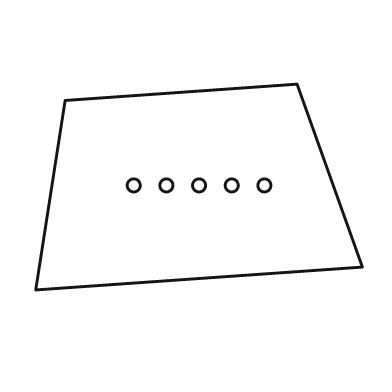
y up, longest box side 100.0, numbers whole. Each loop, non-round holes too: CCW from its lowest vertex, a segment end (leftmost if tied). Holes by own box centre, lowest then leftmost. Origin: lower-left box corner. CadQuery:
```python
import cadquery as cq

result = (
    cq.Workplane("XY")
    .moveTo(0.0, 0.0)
    .lineTo(100.0, 7.0)
    .lineTo(80.0, 63.0)
    .lineTo(9.0, 58.0)
    .close()
    .moveTo(30.0, 32.0)
    .circle(2.0)
    .moveTo(40.0, 32.0)
    .circle(2.0)
    .moveTo(50.0, 32.0)
    .circle(2.0)
    .moveTo(60.0, 32.0)
    .circle(2.0)
    .moveTo(70.0, 32.0)
    .circle(2.0)
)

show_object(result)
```